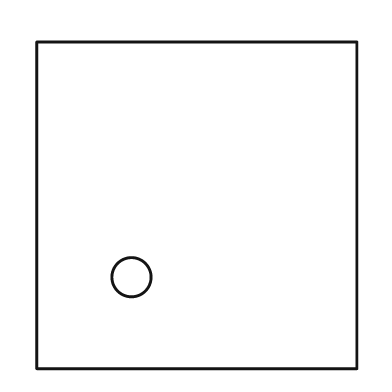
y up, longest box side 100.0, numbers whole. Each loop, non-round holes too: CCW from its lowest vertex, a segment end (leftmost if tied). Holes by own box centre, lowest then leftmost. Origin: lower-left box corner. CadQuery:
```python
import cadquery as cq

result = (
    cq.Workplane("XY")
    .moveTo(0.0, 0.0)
    .lineTo(98.0, 0.0)
    .lineTo(98.0, 100.0)
    .lineTo(0.0, 100.0)
    .close()
    .moveTo(29.0, 28.0)
    .circle(6.0)
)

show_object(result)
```